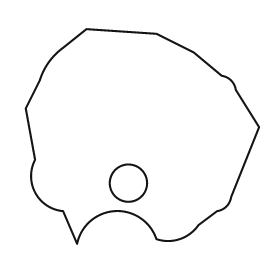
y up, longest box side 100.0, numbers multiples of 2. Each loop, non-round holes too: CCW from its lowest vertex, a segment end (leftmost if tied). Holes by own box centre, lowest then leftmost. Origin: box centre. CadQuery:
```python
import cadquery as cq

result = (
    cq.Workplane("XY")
    .moveTo(-28.0, -46.0)
    .threePointArc((-12.0, -32.0), (6.0, -44.0))
    .threePointArc((16.0, -44.0), (24.0, -38.0))
    .lineTo(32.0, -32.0)
    .threePointArc((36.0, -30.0), (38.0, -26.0))
    .lineTo(50.0, 4.0)
    .lineTo(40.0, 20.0)
    .threePointArc((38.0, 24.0), (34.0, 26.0))
    .lineTo(22.0, 36.0)
    .lineTo(6.0, 44.0)
    .lineTo(-24.0, 46.0)
    .lineTo(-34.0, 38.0)
    .threePointArc((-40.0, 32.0), (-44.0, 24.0))
    .lineTo(-50.0, 12.0)
    .lineTo(-46.0, -10.0)
    .threePointArc((-46.0, -24.0), (-34.0, -32.0))
    .close()
    .moveTo(-6.0, -20.0)
    .circle(8.0)
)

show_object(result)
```